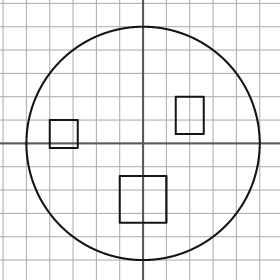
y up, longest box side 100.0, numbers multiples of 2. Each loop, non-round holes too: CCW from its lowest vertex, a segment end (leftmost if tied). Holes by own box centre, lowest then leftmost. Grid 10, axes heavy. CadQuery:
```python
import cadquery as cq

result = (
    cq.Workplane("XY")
    .moveTo(0.0, 0.0)
    .circle(50.0)
    .moveTo(-10.0, -34.0)
    .lineTo(10.0, -34.0)
    .lineTo(10.0, -14.0)
    .lineTo(-10.0, -14.0)
    .close()
    .moveTo(-40.0, -2.0)
    .lineTo(-28.0, -2.0)
    .lineTo(-28.0, 10.0)
    .lineTo(-40.0, 10.0)
    .close()
    .moveTo(14.0, 4.0)
    .lineTo(26.0, 4.0)
    .lineTo(26.0, 20.0)
    .lineTo(14.0, 20.0)
    .close()
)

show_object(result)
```